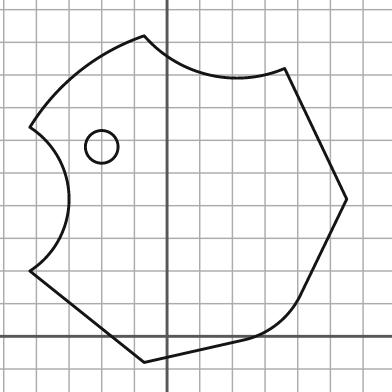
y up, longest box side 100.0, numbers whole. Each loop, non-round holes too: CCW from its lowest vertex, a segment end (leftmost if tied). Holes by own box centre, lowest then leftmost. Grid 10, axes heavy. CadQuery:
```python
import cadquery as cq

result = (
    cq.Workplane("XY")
    .moveTo(-7.0, -8.0)
    .lineTo(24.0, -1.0)
    .threePointArc((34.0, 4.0), (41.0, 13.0))
    .lineTo(55.0, 42.0)
    .lineTo(36.0, 82.0)
    .threePointArc((13.0, 80.0), (-7.0, 92.0))
    .threePointArc((-27.0, 81.0), (-42.0, 64.0))
    .threePointArc((-30.0, 42.0), (-42.0, 20.0))
    .close()
    .moveTo(-20.0, 58.0)
    .circle(5.0)
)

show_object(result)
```